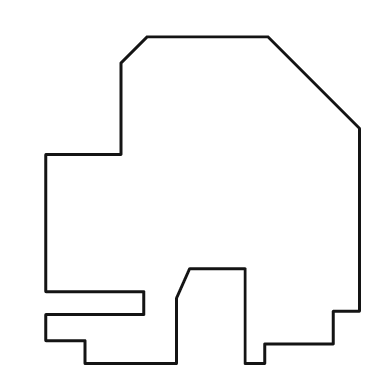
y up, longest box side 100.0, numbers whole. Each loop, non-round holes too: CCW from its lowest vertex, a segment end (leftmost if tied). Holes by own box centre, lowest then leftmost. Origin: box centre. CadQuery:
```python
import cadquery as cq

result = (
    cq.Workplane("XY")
    .moveTo(-36.0, -50.0)
    .lineTo(-8.0, -50.0)
    .lineTo(-8.0, -30.0)
    .lineTo(-4.0, -21.0)
    .lineTo(13.0, -21.0)
    .lineTo(13.0, -50.0)
    .lineTo(19.0, -50.0)
    .lineTo(19.0, -44.0)
    .lineTo(40.0, -44.0)
    .lineTo(40.0, -34.0)
    .lineTo(48.0, -34.0)
    .lineTo(48.0, 22.0)
    .lineTo(20.0, 50.0)
    .lineTo(-17.0, 50.0)
    .lineTo(-25.0, 42.0)
    .lineTo(-25.0, 14.0)
    .lineTo(-48.0, 14.0)
    .lineTo(-48.0, -28.0)
    .lineTo(-18.0, -28.0)
    .lineTo(-18.0, -35.0)
    .lineTo(-48.0, -35.0)
    .lineTo(-48.0, -43.0)
    .lineTo(-36.0, -43.0)
    .close()
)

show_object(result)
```